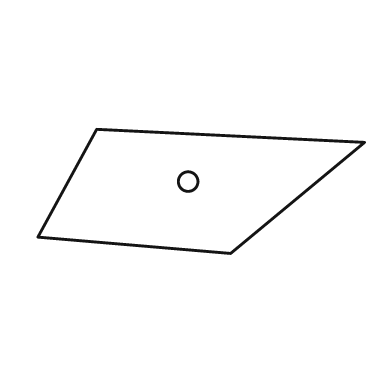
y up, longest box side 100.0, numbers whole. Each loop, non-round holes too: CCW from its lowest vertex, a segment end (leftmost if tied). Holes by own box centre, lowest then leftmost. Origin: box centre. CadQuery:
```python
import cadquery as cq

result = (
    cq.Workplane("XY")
    .moveTo(9.0, -19.0)
    .lineTo(50.0, 15.0)
    .lineTo(-32.0, 19.0)
    .lineTo(-50.0, -14.0)
    .close()
    .moveTo(-4.0, 3.0)
    .circle(3.0)
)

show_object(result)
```